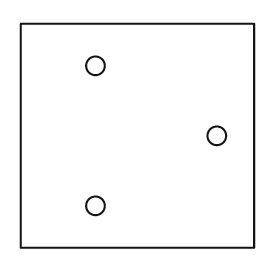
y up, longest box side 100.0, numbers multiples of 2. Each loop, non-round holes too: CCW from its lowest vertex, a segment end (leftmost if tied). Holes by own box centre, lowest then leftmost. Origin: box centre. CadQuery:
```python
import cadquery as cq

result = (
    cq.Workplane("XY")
    .moveTo(-50.0, -48.0)
    .lineTo(50.0, -48.0)
    .lineTo(50.0, 48.0)
    .lineTo(-50.0, 48.0)
    .close()
    .moveTo(-18.0, -30.0)
    .circle(4.0)
    .moveTo(34.0, 0.0)
    .circle(4.0)
    .moveTo(-18.0, 30.0)
    .circle(4.0)
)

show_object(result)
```